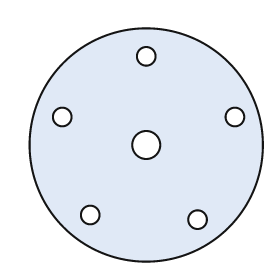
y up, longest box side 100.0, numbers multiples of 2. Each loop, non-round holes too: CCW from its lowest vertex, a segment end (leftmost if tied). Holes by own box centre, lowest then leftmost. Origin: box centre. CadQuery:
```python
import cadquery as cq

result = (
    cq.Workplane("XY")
    .moveTo(0.0, 0.0)
    .circle(50.0)
    .moveTo(22.0, -32.0)
    .circle(4.0)
    .moveTo(-24.0, -30.0)
    .circle(4.0)
    .moveTo(0.0, 0.0)
    .circle(6.0)
    .moveTo(-36.0, 12.0)
    .circle(4.0)
    .moveTo(38.0, 12.0)
    .circle(4.0)
    .moveTo(0.0, 38.0)
    .circle(4.0)
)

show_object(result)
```